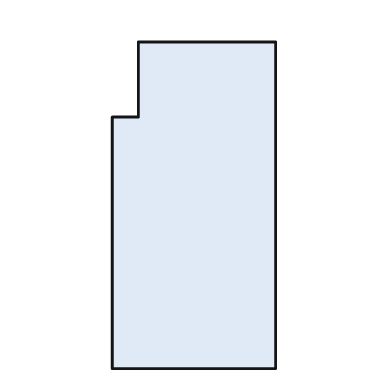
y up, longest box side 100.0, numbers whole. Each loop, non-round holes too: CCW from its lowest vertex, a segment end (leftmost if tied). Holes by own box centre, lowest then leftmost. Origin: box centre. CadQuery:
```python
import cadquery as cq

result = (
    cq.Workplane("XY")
    .moveTo(-25.0, -50.0)
    .lineTo(25.0, -50.0)
    .lineTo(25.0, 50.0)
    .lineTo(-17.0, 50.0)
    .lineTo(-17.0, 27.0)
    .lineTo(-25.0, 27.0)
    .close()
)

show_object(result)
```